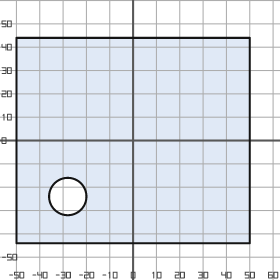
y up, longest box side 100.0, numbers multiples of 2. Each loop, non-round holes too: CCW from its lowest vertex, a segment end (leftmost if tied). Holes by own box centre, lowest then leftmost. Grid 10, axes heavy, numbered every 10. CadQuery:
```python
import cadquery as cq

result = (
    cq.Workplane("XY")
    .moveTo(-50.0, -44.0)
    .lineTo(50.0, -44.0)
    .lineTo(50.0, 44.0)
    .lineTo(-50.0, 44.0)
    .close()
    .moveTo(-28.0, -24.0)
    .circle(8.0)
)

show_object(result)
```